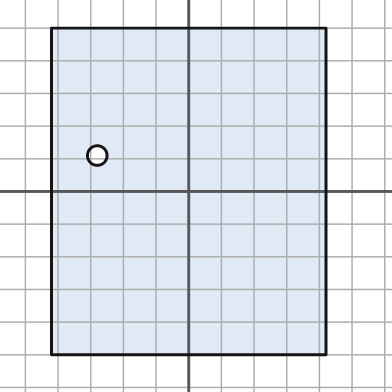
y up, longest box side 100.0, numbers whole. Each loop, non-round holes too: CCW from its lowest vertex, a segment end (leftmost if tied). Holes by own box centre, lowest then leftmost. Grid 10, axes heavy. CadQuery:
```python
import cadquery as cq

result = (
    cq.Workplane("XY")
    .moveTo(-42.0, -50.0)
    .lineTo(42.0, -50.0)
    .lineTo(42.0, 50.0)
    .lineTo(-42.0, 50.0)
    .close()
    .moveTo(-28.0, 11.0)
    .circle(3.0)
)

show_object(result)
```